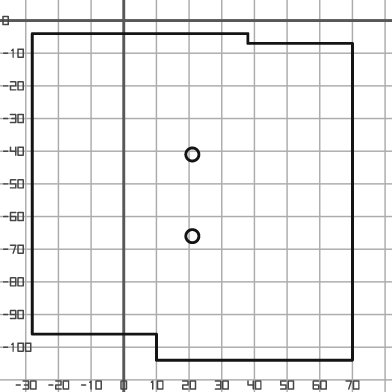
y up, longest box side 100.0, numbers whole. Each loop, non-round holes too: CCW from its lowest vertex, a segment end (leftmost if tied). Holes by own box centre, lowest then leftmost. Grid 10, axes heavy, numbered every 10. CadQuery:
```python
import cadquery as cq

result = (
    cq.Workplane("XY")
    .moveTo(10.0, -104.0)
    .lineTo(70.0, -104.0)
    .lineTo(70.0, -7.0)
    .lineTo(38.0, -7.0)
    .lineTo(38.0, -4.0)
    .lineTo(-28.0, -4.0)
    .lineTo(-28.0, -96.0)
    .lineTo(10.0, -96.0)
    .close()
    .moveTo(21.0, -66.0)
    .circle(2.0)
    .moveTo(21.0, -41.0)
    .circle(2.0)
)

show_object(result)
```